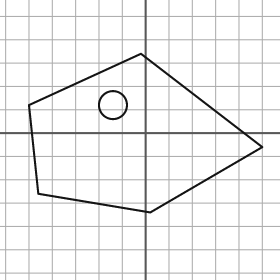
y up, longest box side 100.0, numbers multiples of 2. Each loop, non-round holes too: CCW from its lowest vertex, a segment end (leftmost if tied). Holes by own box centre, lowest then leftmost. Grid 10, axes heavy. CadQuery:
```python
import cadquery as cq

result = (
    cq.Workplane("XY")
    .moveTo(2.0, -34.0)
    .lineTo(50.0, -6.0)
    .lineTo(-2.0, 34.0)
    .lineTo(-50.0, 12.0)
    .lineTo(-46.0, -26.0)
    .close()
    .moveTo(-14.0, 12.0)
    .circle(6.0)
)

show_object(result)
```